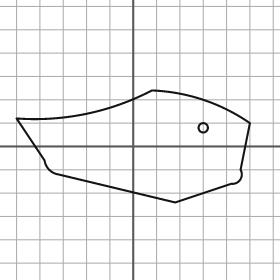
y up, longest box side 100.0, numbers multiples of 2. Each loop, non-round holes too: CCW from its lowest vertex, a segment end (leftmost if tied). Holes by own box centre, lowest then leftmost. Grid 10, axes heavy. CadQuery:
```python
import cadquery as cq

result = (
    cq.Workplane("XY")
    .moveTo(18.0, -24.0)
    .lineTo(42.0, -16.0)
    .threePointArc((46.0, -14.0), (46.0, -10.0))
    .lineTo(50.0, 10.0)
    .threePointArc((30.0, 20.0), (8.0, 24.0))
    .threePointArc((-20.0, 14.0), (-50.0, 12.0))
    .lineTo(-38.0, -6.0)
    .threePointArc((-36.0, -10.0), (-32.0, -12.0))
    .close()
    .moveTo(30.0, 8.0)
    .circle(2.0)
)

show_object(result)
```